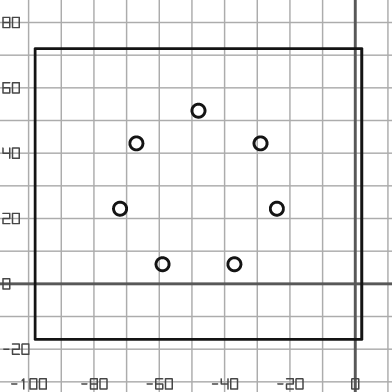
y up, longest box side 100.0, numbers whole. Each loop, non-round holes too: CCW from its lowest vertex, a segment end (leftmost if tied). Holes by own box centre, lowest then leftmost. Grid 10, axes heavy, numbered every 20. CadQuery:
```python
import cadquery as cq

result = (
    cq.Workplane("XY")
    .moveTo(-98.0, -17.0)
    .lineTo(2.0, -17.0)
    .lineTo(2.0, 72.0)
    .lineTo(-98.0, 72.0)
    .close()
    .moveTo(-59.0, 6.0)
    .circle(2.0)
    .moveTo(-37.0, 6.0)
    .circle(2.0)
    .moveTo(-72.0, 23.0)
    .circle(2.0)
    .moveTo(-24.0, 23.0)
    .circle(2.0)
    .moveTo(-67.0, 43.0)
    .circle(2.0)
    .moveTo(-29.0, 43.0)
    .circle(2.0)
    .moveTo(-48.0, 53.0)
    .circle(2.0)
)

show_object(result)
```